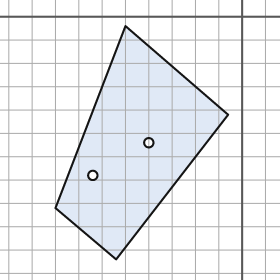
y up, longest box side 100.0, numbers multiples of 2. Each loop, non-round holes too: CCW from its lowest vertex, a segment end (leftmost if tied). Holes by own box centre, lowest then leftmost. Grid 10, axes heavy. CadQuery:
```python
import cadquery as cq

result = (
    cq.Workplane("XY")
    .moveTo(-54.0, -104.0)
    .lineTo(-6.0, -42.0)
    .lineTo(-50.0, -4.0)
    .lineTo(-80.0, -82.0)
    .close()
    .moveTo(-64.0, -68.0)
    .circle(2.0)
    .moveTo(-40.0, -54.0)
    .circle(2.0)
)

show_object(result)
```